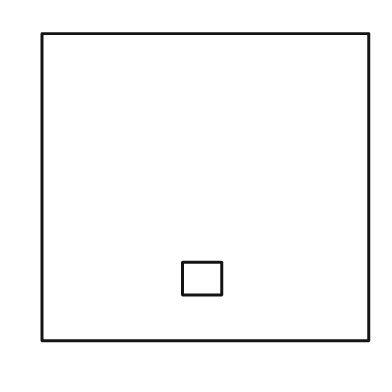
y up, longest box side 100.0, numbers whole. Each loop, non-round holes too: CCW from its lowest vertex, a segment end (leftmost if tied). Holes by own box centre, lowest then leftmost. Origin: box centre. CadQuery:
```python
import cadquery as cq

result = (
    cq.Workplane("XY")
    .moveTo(-50.0, -47.0)
    .lineTo(50.0, -47.0)
    .lineTo(50.0, 47.0)
    .lineTo(-50.0, 47.0)
    .close()
    .moveTo(-7.0, -33.0)
    .lineTo(5.0, -33.0)
    .lineTo(5.0, -23.0)
    .lineTo(-7.0, -23.0)
    .close()
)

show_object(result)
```